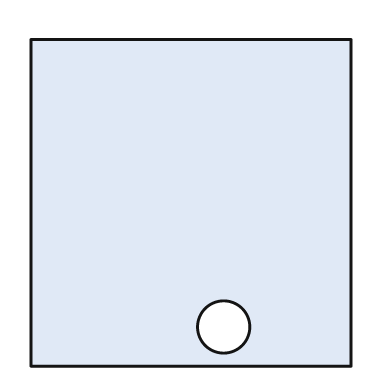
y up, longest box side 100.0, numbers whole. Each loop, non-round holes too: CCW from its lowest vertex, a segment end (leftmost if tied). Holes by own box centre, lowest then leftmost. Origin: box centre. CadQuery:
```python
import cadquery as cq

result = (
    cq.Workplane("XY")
    .moveTo(-49.0, -50.0)
    .lineTo(49.0, -50.0)
    .lineTo(49.0, 50.0)
    .lineTo(-49.0, 50.0)
    .close()
    .moveTo(10.0, -38.0)
    .circle(8.0)
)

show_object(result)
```